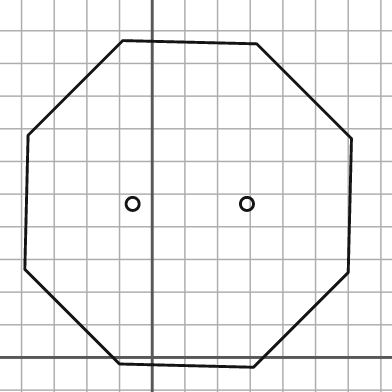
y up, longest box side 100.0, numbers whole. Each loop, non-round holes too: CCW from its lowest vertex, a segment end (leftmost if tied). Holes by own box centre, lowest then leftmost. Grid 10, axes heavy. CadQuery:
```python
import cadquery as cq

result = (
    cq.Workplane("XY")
    .moveTo(31.0, -3.0)
    .lineTo(60.0, 26.0)
    .lineTo(61.0, 67.0)
    .lineTo(32.0, 96.0)
    .lineTo(-9.0, 97.0)
    .lineTo(-38.0, 68.0)
    .lineTo(-39.0, 27.0)
    .lineTo(-10.0, -2.0)
    .close()
    .moveTo(-6.0, 47.0)
    .circle(2.0)
    .moveTo(29.0, 47.0)
    .circle(2.0)
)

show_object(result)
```